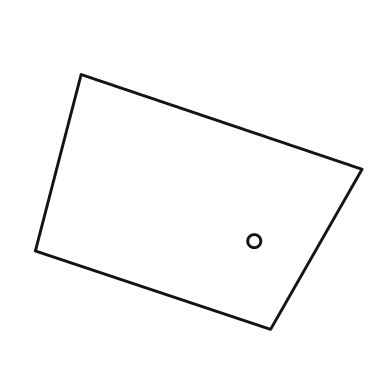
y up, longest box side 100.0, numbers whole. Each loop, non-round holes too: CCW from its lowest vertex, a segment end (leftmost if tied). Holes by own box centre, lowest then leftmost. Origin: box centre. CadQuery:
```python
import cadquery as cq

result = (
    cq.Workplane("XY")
    .moveTo(22.0, -39.0)
    .lineTo(50.0, 10.0)
    .lineTo(-36.0, 39.0)
    .lineTo(-50.0, -15.0)
    .close()
    .moveTo(17.0, -12.0)
    .circle(2.0)
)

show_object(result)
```